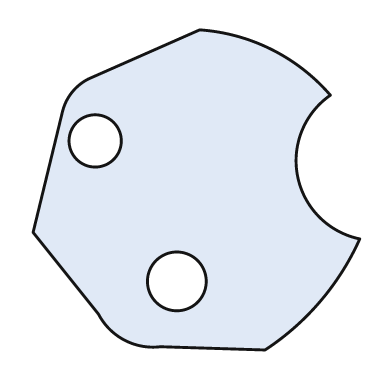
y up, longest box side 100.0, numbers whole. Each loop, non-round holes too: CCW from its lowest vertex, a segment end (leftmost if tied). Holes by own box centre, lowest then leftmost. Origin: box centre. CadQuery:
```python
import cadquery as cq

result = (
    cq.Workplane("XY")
    .moveTo(21.0, -49.0)
    .threePointArc((38.0, -34.0), (50.0, -15.0))
    .threePointArc((31.0, 4.0), (41.0, 29.0))
    .threePointArc((23.0, 43.0), (1.0, 49.0))
    .lineTo(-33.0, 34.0)
    .threePointArc((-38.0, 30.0), (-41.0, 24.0))
    .lineTo(-50.0, -13.0)
    .lineTo(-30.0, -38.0)
    .threePointArc((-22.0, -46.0), (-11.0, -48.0))
    .close()
    .moveTo(-6.0, -28.0)
    .circle(9.0)
    .moveTo(-31.0, 15.0)
    .circle(8.0)
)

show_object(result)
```